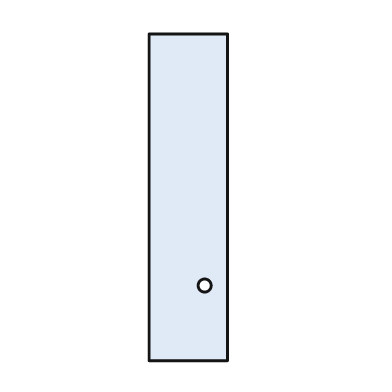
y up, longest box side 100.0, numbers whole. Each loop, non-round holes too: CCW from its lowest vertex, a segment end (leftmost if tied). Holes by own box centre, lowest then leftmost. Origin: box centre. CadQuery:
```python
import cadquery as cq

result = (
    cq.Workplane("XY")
    .moveTo(-12.0, -50.0)
    .lineTo(12.0, -50.0)
    .lineTo(12.0, 50.0)
    .lineTo(-12.0, 50.0)
    .close()
    .moveTo(5.0, -27.0)
    .circle(2.0)
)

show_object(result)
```